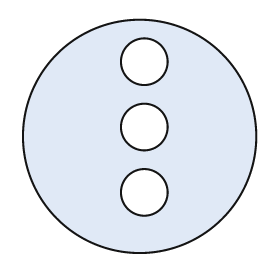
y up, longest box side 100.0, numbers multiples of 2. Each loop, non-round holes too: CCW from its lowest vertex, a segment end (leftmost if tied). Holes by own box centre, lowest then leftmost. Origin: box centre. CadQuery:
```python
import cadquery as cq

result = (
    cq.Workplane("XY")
    .moveTo(0.0, 0.0)
    .circle(50.0)
    .moveTo(2.0, -24.0)
    .circle(10.0)
    .moveTo(2.0, 4.0)
    .circle(10.0)
    .moveTo(2.0, 32.0)
    .circle(10.0)
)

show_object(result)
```